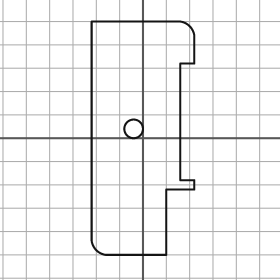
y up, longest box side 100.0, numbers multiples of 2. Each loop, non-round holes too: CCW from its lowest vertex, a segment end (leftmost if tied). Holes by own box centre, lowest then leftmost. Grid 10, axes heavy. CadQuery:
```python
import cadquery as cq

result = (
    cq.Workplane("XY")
    .moveTo(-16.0, -50.0)
    .lineTo(10.0, -50.0)
    .lineTo(10.0, -22.0)
    .lineTo(22.0, -22.0)
    .lineTo(22.0, -18.0)
    .lineTo(16.0, -18.0)
    .lineTo(16.0, 32.0)
    .lineTo(22.0, 32.0)
    .lineTo(22.0, 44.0)
    .threePointArc((20.0, 48.0), (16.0, 50.0))
    .lineTo(-22.0, 50.0)
    .lineTo(-22.0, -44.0)
    .threePointArc((-20.0, -48.0), (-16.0, -50.0))
    .close()
    .moveTo(-4.0, 4.0)
    .circle(4.0)
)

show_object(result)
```